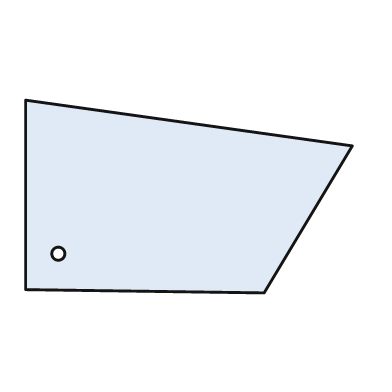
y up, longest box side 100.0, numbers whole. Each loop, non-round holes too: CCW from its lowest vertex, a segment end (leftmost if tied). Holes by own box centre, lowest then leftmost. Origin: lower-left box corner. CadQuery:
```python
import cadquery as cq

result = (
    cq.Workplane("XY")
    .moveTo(73.0, 0.0)
    .lineTo(100.0, 45.0)
    .lineTo(0.0, 59.0)
    .lineTo(0.0, 1.0)
    .close()
    .moveTo(10.0, 12.0)
    .circle(2.0)
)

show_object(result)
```